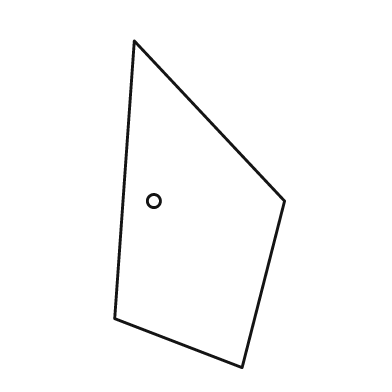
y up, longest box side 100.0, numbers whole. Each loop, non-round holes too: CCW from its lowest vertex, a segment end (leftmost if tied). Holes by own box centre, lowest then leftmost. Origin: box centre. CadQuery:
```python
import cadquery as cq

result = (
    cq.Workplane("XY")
    .moveTo(13.0, -50.0)
    .lineTo(26.0, 1.0)
    .lineTo(-20.0, 50.0)
    .lineTo(-26.0, -35.0)
    .close()
    .moveTo(-14.0, 1.0)
    .circle(2.0)
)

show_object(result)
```